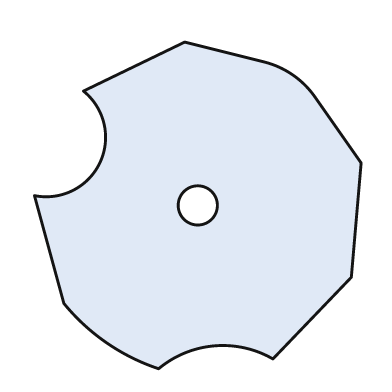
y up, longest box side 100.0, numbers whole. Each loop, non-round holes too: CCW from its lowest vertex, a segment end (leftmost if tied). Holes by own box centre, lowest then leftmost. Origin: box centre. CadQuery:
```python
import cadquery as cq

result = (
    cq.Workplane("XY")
    .moveTo(-12.0, -50.0)
    .threePointArc((5.0, -43.0), (23.0, -47.0))
    .lineTo(47.0, -22.0)
    .lineTo(50.0, 13.0)
    .lineTo(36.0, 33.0)
    .threePointArc((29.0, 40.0), (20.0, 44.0))
    .lineTo(-4.0, 50.0)
    .lineTo(-35.0, 35.0)
    .threePointArc((-30.0, 13.0), (-50.0, 3.0))
    .lineTo(-41.0, -30.0)
    .threePointArc((-28.0, -42.0), (-12.0, -50.0))
    .close()
    .moveTo(0.0, 0.0)
    .circle(6.0)
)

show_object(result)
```